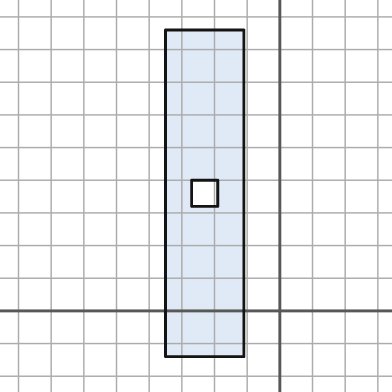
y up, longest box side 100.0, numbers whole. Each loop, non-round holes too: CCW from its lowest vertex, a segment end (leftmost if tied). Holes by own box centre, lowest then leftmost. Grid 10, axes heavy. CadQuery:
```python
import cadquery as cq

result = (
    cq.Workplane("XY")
    .moveTo(-35.0, -14.0)
    .lineTo(-11.0, -14.0)
    .lineTo(-11.0, 86.0)
    .lineTo(-35.0, 86.0)
    .close()
    .moveTo(-27.0, 32.0)
    .lineTo(-19.0, 32.0)
    .lineTo(-19.0, 40.0)
    .lineTo(-27.0, 40.0)
    .close()
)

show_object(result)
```